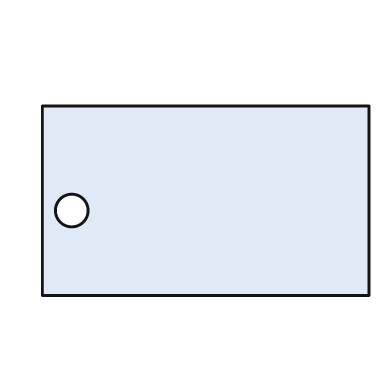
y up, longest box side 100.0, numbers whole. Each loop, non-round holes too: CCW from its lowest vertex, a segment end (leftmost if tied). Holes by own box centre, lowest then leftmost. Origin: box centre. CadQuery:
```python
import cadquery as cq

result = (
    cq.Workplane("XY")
    .moveTo(-50.0, -29.0)
    .lineTo(50.0, -29.0)
    .lineTo(50.0, 29.0)
    .lineTo(-50.0, 29.0)
    .close()
    .moveTo(-41.0, -3.0)
    .circle(5.0)
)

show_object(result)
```